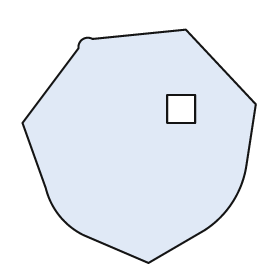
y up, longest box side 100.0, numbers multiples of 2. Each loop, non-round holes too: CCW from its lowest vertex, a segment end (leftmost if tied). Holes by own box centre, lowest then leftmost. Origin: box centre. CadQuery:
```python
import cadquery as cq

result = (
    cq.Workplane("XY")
    .moveTo(4.0, -50.0)
    .lineTo(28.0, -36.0)
    .threePointArc((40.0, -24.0), (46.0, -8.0))
    .lineTo(50.0, 18.0)
    .lineTo(20.0, 50.0)
    .lineTo(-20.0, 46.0)
    .threePointArc((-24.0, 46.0), (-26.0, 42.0))
    .lineTo(-50.0, 10.0)
    .lineTo(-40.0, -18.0)
    .threePointArc((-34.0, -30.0), (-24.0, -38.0))
    .close()
    .moveTo(12.0, 10.0)
    .lineTo(24.0, 10.0)
    .lineTo(24.0, 22.0)
    .lineTo(12.0, 22.0)
    .close()
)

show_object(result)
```